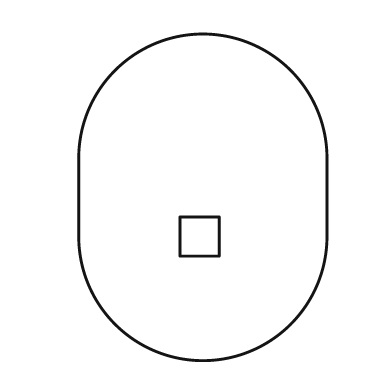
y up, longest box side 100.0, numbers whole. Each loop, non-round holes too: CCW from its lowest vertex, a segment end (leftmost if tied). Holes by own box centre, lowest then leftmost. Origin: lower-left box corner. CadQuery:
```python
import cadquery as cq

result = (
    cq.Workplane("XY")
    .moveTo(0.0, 38.0)
    .threePointArc((38.0, 0.0), (76.0, 38.0))
    .lineTo(76.0, 62.0)
    .threePointArc((38.0, 100.0), (0.0, 62.0))
    .close()
    .moveTo(31.0, 32.0)
    .lineTo(43.0, 32.0)
    .lineTo(43.0, 44.0)
    .lineTo(31.0, 44.0)
    .close()
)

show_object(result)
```